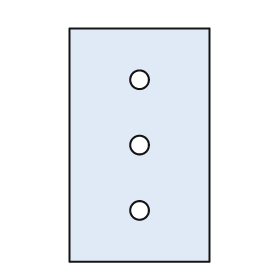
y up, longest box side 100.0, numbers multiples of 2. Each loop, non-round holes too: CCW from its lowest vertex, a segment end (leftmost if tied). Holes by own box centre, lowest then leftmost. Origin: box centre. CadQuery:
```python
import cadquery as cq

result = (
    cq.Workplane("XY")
    .moveTo(-30.0, -50.0)
    .lineTo(30.0, -50.0)
    .lineTo(30.0, 50.0)
    .lineTo(-30.0, 50.0)
    .close()
    .moveTo(0.0, -28.0)
    .circle(4.0)
    .moveTo(0.0, 0.0)
    .circle(4.0)
    .moveTo(0.0, 28.0)
    .circle(4.0)
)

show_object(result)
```